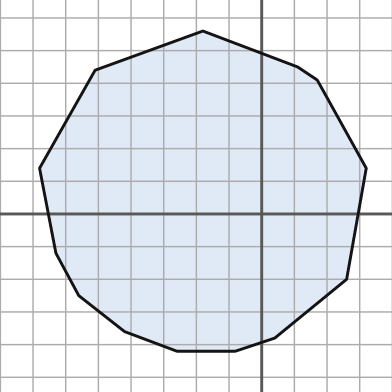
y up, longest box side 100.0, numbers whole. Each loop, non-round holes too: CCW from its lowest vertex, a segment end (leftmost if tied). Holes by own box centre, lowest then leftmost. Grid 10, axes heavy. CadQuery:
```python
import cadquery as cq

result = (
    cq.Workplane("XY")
    .moveTo(-26.0, -42.0)
    .lineTo(-8.0, -42.0)
    .lineTo(4.0, -38.0)
    .lineTo(26.0, -20.0)
    .lineTo(32.0, 14.0)
    .lineTo(17.0, 41.0)
    .lineTo(11.0, 45.0)
    .lineTo(-18.0, 56.0)
    .lineTo(-51.0, 44.0)
    .lineTo(-68.0, 14.0)
    .lineTo(-63.0, -12.0)
    .lineTo(-56.0, -25.0)
    .lineTo(-42.0, -36.0)
    .close()
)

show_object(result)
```